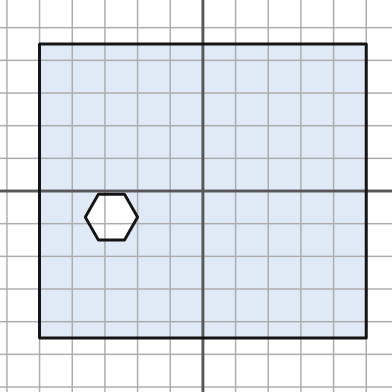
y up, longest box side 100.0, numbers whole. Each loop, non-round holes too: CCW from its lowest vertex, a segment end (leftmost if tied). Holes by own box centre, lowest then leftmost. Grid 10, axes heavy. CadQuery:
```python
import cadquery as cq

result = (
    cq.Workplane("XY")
    .moveTo(-50.0, -45.0)
    .lineTo(50.0, -45.0)
    .lineTo(50.0, 45.0)
    .lineTo(-50.0, 45.0)
    .close()
    .moveTo(-32.0, -15.0)
    .lineTo(-24.0, -15.0)
    .lineTo(-20.0, -8.0)
    .lineTo(-24.0, -1.0)
    .lineTo(-32.0, -1.0)
    .lineTo(-36.0, -8.0)
    .close()
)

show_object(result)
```